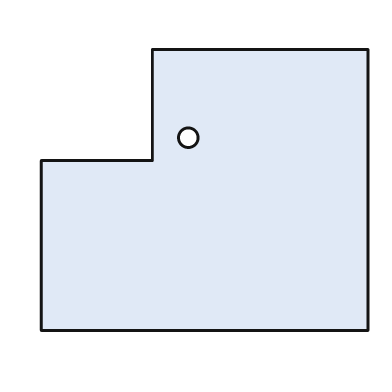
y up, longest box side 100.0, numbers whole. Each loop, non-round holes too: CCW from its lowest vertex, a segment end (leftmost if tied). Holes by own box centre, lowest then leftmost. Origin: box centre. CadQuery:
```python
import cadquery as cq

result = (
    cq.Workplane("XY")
    .moveTo(-50.0, -43.0)
    .lineTo(50.0, -43.0)
    .lineTo(50.0, 43.0)
    .lineTo(-16.0, 43.0)
    .lineTo(-16.0, 9.0)
    .lineTo(-50.0, 9.0)
    .close()
    .moveTo(-5.0, 16.0)
    .circle(3.0)
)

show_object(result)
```